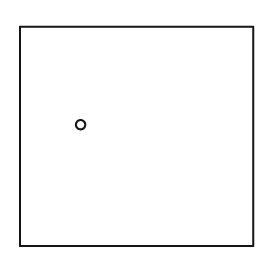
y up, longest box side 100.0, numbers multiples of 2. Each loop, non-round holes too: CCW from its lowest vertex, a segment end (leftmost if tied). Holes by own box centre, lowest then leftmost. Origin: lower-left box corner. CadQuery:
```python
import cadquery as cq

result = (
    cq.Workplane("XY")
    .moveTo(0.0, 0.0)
    .lineTo(100.0, 0.0)
    .lineTo(100.0, 94.0)
    .lineTo(0.0, 94.0)
    .close()
    .moveTo(26.0, 52.0)
    .circle(2.0)
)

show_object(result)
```